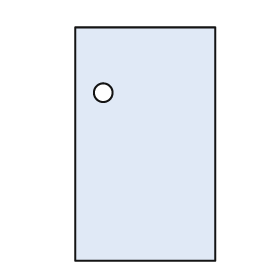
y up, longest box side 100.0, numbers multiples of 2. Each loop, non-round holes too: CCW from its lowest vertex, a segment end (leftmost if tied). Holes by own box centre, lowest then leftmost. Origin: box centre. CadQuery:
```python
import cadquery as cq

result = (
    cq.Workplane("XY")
    .moveTo(-30.0, -50.0)
    .lineTo(30.0, -50.0)
    .lineTo(30.0, 50.0)
    .lineTo(-30.0, 50.0)
    .close()
    .moveTo(-18.0, 22.0)
    .circle(4.0)
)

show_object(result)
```